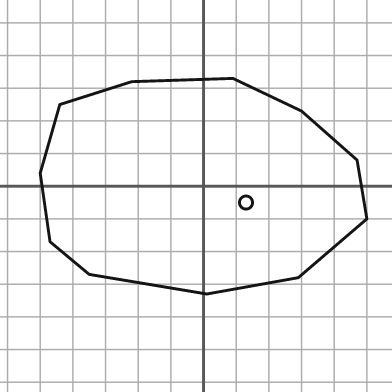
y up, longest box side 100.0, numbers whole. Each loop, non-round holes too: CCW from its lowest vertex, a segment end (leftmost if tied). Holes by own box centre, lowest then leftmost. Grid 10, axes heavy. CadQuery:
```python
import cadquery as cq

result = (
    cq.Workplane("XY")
    .moveTo(1.0, -33.0)
    .lineTo(29.0, -28.0)
    .lineTo(50.0, -10.0)
    .lineTo(47.0, 8.0)
    .lineTo(30.0, 23.0)
    .lineTo(9.0, 33.0)
    .lineTo(-22.0, 32.0)
    .lineTo(-44.0, 25.0)
    .lineTo(-50.0, 4.0)
    .lineTo(-47.0, -17.0)
    .lineTo(-35.0, -27.0)
    .close()
    .moveTo(13.0, -5.0)
    .circle(2.0)
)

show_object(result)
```